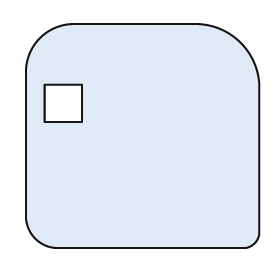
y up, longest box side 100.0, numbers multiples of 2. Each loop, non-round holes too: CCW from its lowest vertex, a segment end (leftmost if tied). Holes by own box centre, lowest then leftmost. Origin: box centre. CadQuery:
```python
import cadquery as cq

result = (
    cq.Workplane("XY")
    .moveTo(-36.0, -48.0)
    .lineTo(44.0, -48.0)
    .threePointArc((48.0, -46.0), (50.0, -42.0))
    .lineTo(50.0, 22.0)
    .threePointArc((42.0, 40.0), (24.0, 48.0))
    .lineTo(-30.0, 48.0)
    .threePointArc((-44.0, 42.0), (-50.0, 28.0))
    .lineTo(-50.0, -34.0)
    .threePointArc((-46.0, -44.0), (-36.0, -48.0))
    .close()
    .moveTo(-42.0, 6.0)
    .lineTo(-26.0, 6.0)
    .lineTo(-26.0, 22.0)
    .lineTo(-42.0, 22.0)
    .close()
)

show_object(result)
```